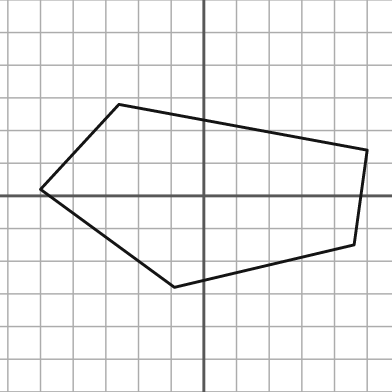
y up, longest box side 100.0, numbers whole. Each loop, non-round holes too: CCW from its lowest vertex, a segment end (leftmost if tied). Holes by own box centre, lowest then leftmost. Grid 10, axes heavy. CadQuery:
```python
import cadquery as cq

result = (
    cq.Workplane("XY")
    .moveTo(-9.0, -28.0)
    .lineTo(46.0, -15.0)
    .lineTo(50.0, 14.0)
    .lineTo(-26.0, 28.0)
    .lineTo(-50.0, 2.0)
    .close()
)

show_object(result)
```